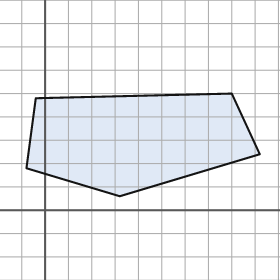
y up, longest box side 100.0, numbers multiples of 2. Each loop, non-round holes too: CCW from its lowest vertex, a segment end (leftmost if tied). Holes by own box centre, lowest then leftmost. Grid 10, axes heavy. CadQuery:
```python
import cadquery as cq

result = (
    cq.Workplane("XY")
    .moveTo(32.0, 6.0)
    .lineTo(92.0, 24.0)
    .lineTo(80.0, 50.0)
    .lineTo(-4.0, 48.0)
    .lineTo(-8.0, 18.0)
    .close()
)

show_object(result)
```